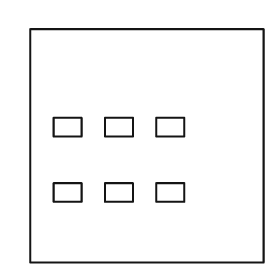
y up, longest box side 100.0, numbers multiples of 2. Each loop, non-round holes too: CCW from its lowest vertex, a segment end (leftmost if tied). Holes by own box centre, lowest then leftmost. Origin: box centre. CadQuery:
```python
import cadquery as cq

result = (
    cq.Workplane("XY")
    .moveTo(-50.0, -50.0)
    .lineTo(50.0, -50.0)
    .lineTo(50.0, 50.0)
    .lineTo(-50.0, 50.0)
    .close()
    .moveTo(-40.0, -24.0)
    .lineTo(-28.0, -24.0)
    .lineTo(-28.0, -16.0)
    .lineTo(-40.0, -16.0)
    .close()
    .moveTo(-18.0, -24.0)
    .lineTo(-6.0, -24.0)
    .lineTo(-6.0, -16.0)
    .lineTo(-18.0, -16.0)
    .close()
    .moveTo(4.0, -24.0)
    .lineTo(16.0, -24.0)
    .lineTo(16.0, -16.0)
    .lineTo(4.0, -16.0)
    .close()
    .moveTo(-40.0, 4.0)
    .lineTo(-28.0, 4.0)
    .lineTo(-28.0, 12.0)
    .lineTo(-40.0, 12.0)
    .close()
    .moveTo(-18.0, 4.0)
    .lineTo(-6.0, 4.0)
    .lineTo(-6.0, 12.0)
    .lineTo(-18.0, 12.0)
    .close()
    .moveTo(4.0, 4.0)
    .lineTo(16.0, 4.0)
    .lineTo(16.0, 12.0)
    .lineTo(4.0, 12.0)
    .close()
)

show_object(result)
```